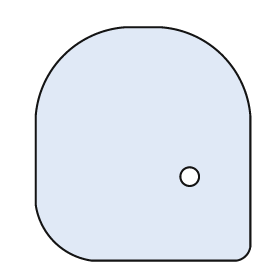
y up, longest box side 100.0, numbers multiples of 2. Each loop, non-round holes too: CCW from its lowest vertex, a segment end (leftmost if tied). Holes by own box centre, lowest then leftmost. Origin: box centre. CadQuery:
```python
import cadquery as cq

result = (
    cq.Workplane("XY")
    .moveTo(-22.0, -50.0)
    .lineTo(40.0, -50.0)
    .threePointArc((44.0, -48.0), (46.0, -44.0))
    .lineTo(46.0, 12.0)
    .threePointArc((34.0, 38.0), (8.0, 50.0))
    .lineTo(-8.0, 50.0)
    .threePointArc((-34.0, 38.0), (-46.0, 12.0))
    .lineTo(-46.0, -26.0)
    .threePointArc((-38.0, -42.0), (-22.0, -50.0))
    .close()
    .moveTo(20.0, -14.0)
    .circle(4.0)
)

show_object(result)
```